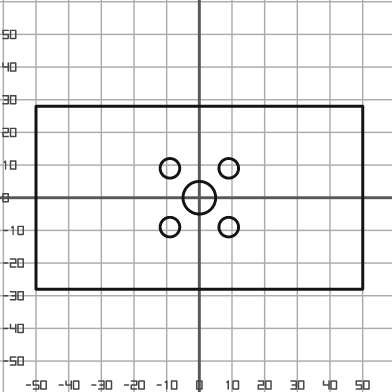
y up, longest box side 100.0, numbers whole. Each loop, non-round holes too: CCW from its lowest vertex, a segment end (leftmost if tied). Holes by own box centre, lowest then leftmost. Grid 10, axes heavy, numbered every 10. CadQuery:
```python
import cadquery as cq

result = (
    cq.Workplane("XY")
    .moveTo(-50.0, -28.0)
    .lineTo(50.0, -28.0)
    .lineTo(50.0, 28.0)
    .lineTo(-50.0, 28.0)
    .close()
    .moveTo(-9.0, -9.0)
    .circle(3.0)
    .moveTo(9.0, -9.0)
    .circle(3.0)
    .moveTo(0.0, 0.0)
    .circle(5.0)
    .moveTo(-9.0, 9.0)
    .circle(3.0)
    .moveTo(9.0, 9.0)
    .circle(3.0)
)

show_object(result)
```